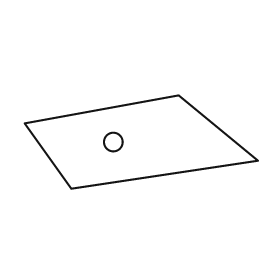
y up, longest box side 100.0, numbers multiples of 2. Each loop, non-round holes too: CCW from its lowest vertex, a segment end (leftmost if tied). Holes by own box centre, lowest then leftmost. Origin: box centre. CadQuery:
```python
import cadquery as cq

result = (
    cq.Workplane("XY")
    .moveTo(-30.0, -20.0)
    .lineTo(50.0, -8.0)
    .lineTo(16.0, 20.0)
    .lineTo(-50.0, 8.0)
    .close()
    .moveTo(-12.0, 0.0)
    .circle(4.0)
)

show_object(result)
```